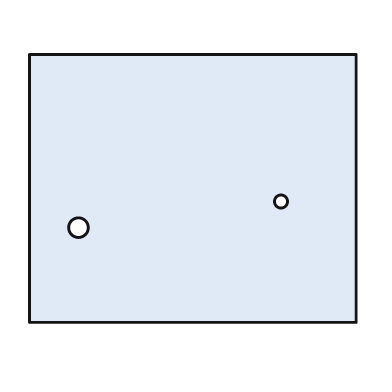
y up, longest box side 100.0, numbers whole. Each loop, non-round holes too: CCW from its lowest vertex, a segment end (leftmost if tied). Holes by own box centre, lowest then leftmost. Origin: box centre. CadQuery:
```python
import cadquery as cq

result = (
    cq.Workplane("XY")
    .moveTo(-50.0, -41.0)
    .lineTo(50.0, -41.0)
    .lineTo(50.0, 41.0)
    .lineTo(-50.0, 41.0)
    .close()
    .moveTo(-35.0, -12.0)
    .circle(3.0)
    .moveTo(27.0, -4.0)
    .circle(2.0)
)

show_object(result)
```